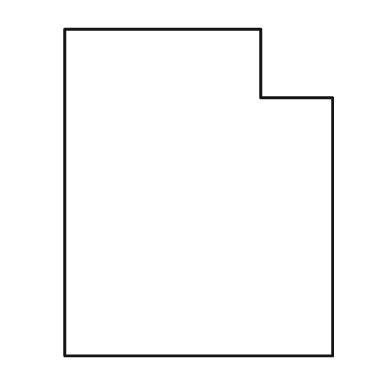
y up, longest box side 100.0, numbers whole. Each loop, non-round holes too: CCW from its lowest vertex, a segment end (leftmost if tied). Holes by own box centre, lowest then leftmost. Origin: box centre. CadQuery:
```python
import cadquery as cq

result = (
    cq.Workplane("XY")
    .moveTo(-41.0, -50.0)
    .lineTo(41.0, -50.0)
    .lineTo(41.0, 29.0)
    .lineTo(19.0, 29.0)
    .lineTo(19.0, 50.0)
    .lineTo(-41.0, 50.0)
    .close()
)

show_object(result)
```